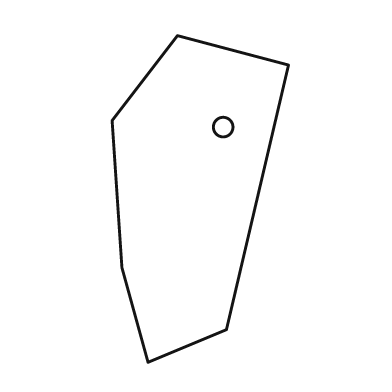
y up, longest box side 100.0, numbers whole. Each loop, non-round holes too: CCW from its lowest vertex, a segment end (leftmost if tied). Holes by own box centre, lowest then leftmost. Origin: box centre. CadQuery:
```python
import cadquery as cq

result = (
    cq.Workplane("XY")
    .moveTo(-16.0, -50.0)
    .lineTo(8.0, -40.0)
    .lineTo(27.0, 41.0)
    .lineTo(-7.0, 50.0)
    .lineTo(-27.0, 24.0)
    .lineTo(-24.0, -21.0)
    .close()
    .moveTo(7.0, 22.0)
    .circle(3.0)
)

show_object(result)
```